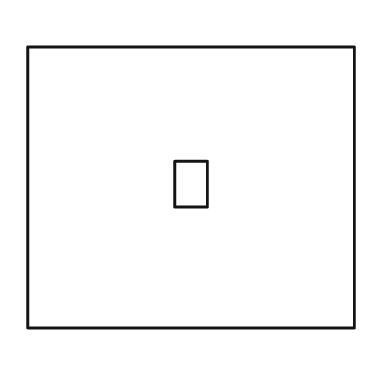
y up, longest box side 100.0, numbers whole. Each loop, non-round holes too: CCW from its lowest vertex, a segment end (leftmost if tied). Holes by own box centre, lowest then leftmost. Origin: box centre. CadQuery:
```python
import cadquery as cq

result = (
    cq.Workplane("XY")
    .moveTo(-50.0, -43.0)
    .lineTo(50.0, -43.0)
    .lineTo(50.0, 43.0)
    .lineTo(-50.0, 43.0)
    .close()
    .moveTo(-5.0, -6.0)
    .lineTo(5.0, -6.0)
    .lineTo(5.0, 8.0)
    .lineTo(-5.0, 8.0)
    .close()
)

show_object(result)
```